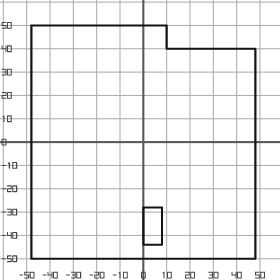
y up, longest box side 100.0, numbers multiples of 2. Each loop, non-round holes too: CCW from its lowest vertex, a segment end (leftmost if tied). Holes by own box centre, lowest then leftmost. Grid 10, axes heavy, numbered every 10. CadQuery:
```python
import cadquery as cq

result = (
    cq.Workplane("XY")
    .moveTo(-48.0, -50.0)
    .lineTo(48.0, -50.0)
    .lineTo(48.0, 40.0)
    .lineTo(10.0, 40.0)
    .lineTo(10.0, 50.0)
    .lineTo(-48.0, 50.0)
    .close()
    .moveTo(0.0, -44.0)
    .lineTo(8.0, -44.0)
    .lineTo(8.0, -28.0)
    .lineTo(0.0, -28.0)
    .close()
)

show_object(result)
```